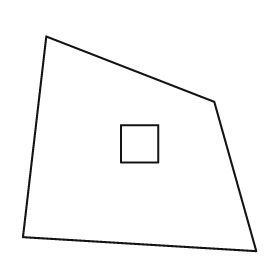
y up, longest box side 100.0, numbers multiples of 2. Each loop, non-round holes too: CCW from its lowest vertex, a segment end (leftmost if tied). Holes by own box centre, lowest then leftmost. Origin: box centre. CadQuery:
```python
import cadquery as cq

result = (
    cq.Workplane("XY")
    .moveTo(50.0, -46.0)
    .lineTo(32.0, 18.0)
    .lineTo(-40.0, 46.0)
    .lineTo(-50.0, -40.0)
    .close()
    .moveTo(-8.0, -8.0)
    .lineTo(8.0, -8.0)
    .lineTo(8.0, 8.0)
    .lineTo(-8.0, 8.0)
    .close()
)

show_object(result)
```